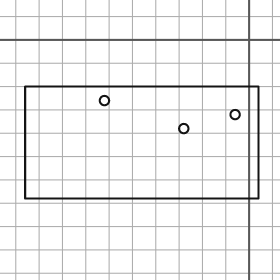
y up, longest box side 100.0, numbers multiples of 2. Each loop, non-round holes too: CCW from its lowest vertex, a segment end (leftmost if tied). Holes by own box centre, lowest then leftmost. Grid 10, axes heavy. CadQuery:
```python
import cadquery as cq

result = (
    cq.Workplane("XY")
    .moveTo(-96.0, -68.0)
    .lineTo(4.0, -68.0)
    .lineTo(4.0, -20.0)
    .lineTo(-96.0, -20.0)
    .close()
    .moveTo(-28.0, -38.0)
    .circle(2.0)
    .moveTo(-6.0, -32.0)
    .circle(2.0)
    .moveTo(-62.0, -26.0)
    .circle(2.0)
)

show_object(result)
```